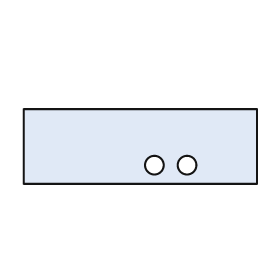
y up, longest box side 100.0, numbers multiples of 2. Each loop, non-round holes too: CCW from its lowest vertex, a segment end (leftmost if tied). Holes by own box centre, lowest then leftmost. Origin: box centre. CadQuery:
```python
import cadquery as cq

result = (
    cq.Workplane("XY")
    .moveTo(-50.0, -16.0)
    .lineTo(50.0, -16.0)
    .lineTo(50.0, 16.0)
    .lineTo(-50.0, 16.0)
    .close()
    .moveTo(6.0, -8.0)
    .circle(4.0)
    .moveTo(20.0, -8.0)
    .circle(4.0)
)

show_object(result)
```